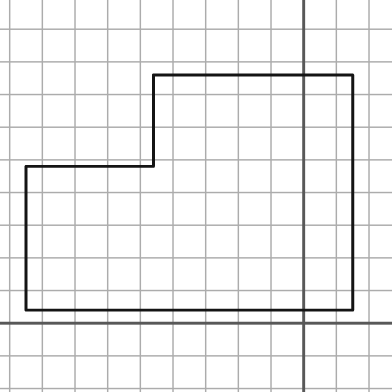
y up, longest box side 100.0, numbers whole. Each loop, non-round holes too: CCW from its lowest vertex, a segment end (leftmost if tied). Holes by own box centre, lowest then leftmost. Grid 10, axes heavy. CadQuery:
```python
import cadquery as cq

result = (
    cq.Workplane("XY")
    .moveTo(-85.0, 4.0)
    .lineTo(15.0, 4.0)
    .lineTo(15.0, 76.0)
    .lineTo(-46.0, 76.0)
    .lineTo(-46.0, 48.0)
    .lineTo(-85.0, 48.0)
    .close()
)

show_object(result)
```